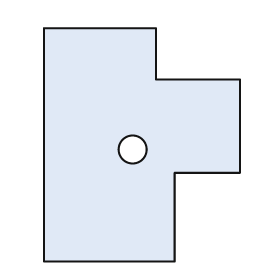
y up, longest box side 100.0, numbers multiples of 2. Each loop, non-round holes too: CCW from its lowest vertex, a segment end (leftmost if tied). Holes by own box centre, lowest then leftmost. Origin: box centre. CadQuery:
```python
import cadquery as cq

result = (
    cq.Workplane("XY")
    .moveTo(-42.0, -50.0)
    .lineTo(14.0, -50.0)
    .lineTo(14.0, -12.0)
    .lineTo(42.0, -12.0)
    .lineTo(42.0, 28.0)
    .lineTo(6.0, 28.0)
    .lineTo(6.0, 50.0)
    .lineTo(-42.0, 50.0)
    .close()
    .moveTo(-4.0, -2.0)
    .circle(6.0)
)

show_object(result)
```